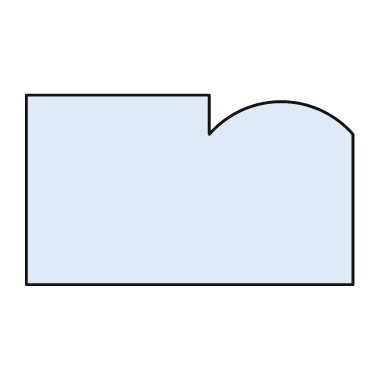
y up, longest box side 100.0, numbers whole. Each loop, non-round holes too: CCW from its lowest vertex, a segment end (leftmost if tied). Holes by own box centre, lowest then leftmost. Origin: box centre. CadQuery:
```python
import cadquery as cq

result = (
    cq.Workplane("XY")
    .moveTo(-50.0, -29.0)
    .lineTo(50.0, -29.0)
    .lineTo(50.0, 17.0)
    .threePointArc((28.0, 27.0), (6.0, 17.0))
    .lineTo(6.0, 29.0)
    .lineTo(-50.0, 29.0)
    .close()
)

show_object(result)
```